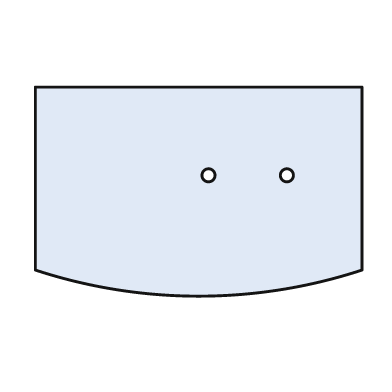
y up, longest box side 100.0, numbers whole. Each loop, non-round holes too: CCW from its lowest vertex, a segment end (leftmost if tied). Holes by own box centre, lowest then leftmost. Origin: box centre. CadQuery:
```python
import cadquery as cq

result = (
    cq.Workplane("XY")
    .moveTo(-50.0, -24.0)
    .threePointArc((0.0, -32.0), (50.0, -24.0))
    .lineTo(50.0, 32.0)
    .lineTo(-50.0, 32.0)
    .close()
    .moveTo(3.0, 5.0)
    .circle(2.0)
    .moveTo(27.0, 5.0)
    .circle(2.0)
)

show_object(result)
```